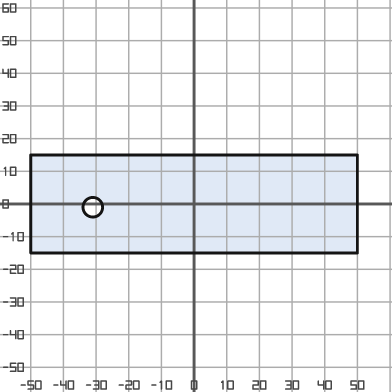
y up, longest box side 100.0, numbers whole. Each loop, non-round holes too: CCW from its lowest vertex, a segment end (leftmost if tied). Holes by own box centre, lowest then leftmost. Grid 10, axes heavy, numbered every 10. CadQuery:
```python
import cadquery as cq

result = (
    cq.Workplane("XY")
    .moveTo(-50.0, -15.0)
    .lineTo(50.0, -15.0)
    .lineTo(50.0, 15.0)
    .lineTo(-50.0, 15.0)
    .close()
    .moveTo(-31.0, -1.0)
    .circle(3.0)
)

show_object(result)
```